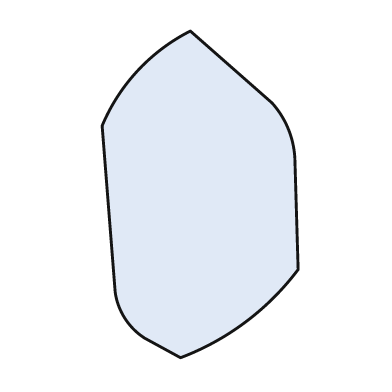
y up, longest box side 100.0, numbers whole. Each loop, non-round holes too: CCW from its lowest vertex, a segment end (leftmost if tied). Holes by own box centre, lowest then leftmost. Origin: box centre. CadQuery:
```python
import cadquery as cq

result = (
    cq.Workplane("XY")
    .moveTo(-6.0, -50.0)
    .threePointArc((14.0, -39.0), (30.0, -23.0))
    .lineTo(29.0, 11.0)
    .threePointArc((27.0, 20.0), (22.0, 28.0))
    .lineTo(-3.0, 50.0)
    .threePointArc((-19.0, 38.0), (-30.0, 21.0))
    .lineTo(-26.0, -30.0)
    .threePointArc((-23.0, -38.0), (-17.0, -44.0))
    .close()
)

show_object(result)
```